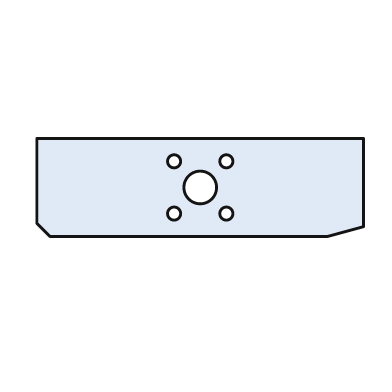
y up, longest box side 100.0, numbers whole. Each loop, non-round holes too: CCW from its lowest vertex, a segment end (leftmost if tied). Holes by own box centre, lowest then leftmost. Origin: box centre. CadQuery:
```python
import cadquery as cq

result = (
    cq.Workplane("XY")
    .moveTo(-46.0, -15.0)
    .lineTo(39.0, -15.0)
    .lineTo(50.0, -12.0)
    .lineTo(50.0, 15.0)
    .lineTo(-50.0, 15.0)
    .lineTo(-50.0, -11.0)
    .close()
    .moveTo(-8.0, -8.0)
    .circle(2.0)
    .moveTo(8.0, -8.0)
    .circle(2.0)
    .moveTo(0.0, 0.0)
    .circle(5.0)
    .moveTo(-8.0, 8.0)
    .circle(2.0)
    .moveTo(8.0, 8.0)
    .circle(2.0)
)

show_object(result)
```